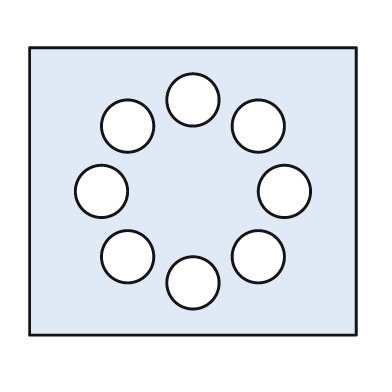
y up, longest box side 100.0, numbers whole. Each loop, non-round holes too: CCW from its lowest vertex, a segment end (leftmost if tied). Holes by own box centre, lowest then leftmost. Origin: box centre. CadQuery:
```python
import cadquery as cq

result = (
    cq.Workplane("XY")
    .moveTo(-50.0, -44.0)
    .lineTo(50.0, -44.0)
    .lineTo(50.0, 44.0)
    .lineTo(-50.0, 44.0)
    .close()
    .moveTo(0.0, -28.0)
    .circle(8.0)
    .moveTo(-20.0, -20.0)
    .circle(8.0)
    .moveTo(20.0, -20.0)
    .circle(8.0)
    .moveTo(-28.0, 0.0)
    .circle(8.0)
    .moveTo(28.0, 0.0)
    .circle(8.0)
    .moveTo(-20.0, 20.0)
    .circle(8.0)
    .moveTo(20.0, 20.0)
    .circle(8.0)
    .moveTo(0.0, 28.0)
    .circle(8.0)
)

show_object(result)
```